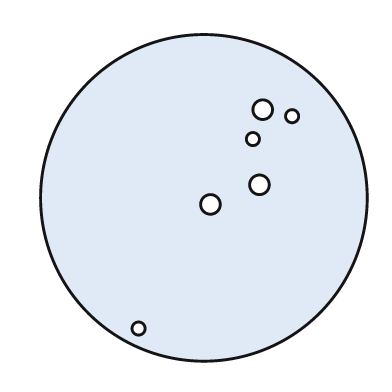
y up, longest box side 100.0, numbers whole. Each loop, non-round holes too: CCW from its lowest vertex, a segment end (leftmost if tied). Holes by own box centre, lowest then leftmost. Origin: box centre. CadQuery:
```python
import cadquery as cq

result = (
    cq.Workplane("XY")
    .moveTo(0.0, 0.0)
    .circle(50.0)
    .moveTo(-20.0, -40.0)
    .circle(2.0)
    .moveTo(2.0, -2.0)
    .circle(3.0)
    .moveTo(17.0, 4.0)
    .circle(3.0)
    .moveTo(15.0, 18.0)
    .circle(2.0)
    .moveTo(27.0, 25.0)
    .circle(2.0)
    .moveTo(18.0, 27.0)
    .circle(3.0)
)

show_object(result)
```